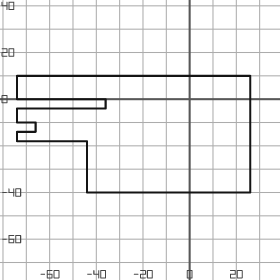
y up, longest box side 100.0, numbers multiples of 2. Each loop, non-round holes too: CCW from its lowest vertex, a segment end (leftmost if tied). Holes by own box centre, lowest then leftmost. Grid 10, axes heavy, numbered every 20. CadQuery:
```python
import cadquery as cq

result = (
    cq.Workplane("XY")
    .moveTo(-44.0, -40.0)
    .lineTo(26.0, -40.0)
    .lineTo(26.0, 10.0)
    .lineTo(-74.0, 10.0)
    .lineTo(-74.0, 0.0)
    .lineTo(-36.0, 0.0)
    .lineTo(-36.0, -4.0)
    .lineTo(-74.0, -4.0)
    .lineTo(-74.0, -10.0)
    .lineTo(-66.0, -10.0)
    .lineTo(-66.0, -14.0)
    .lineTo(-74.0, -14.0)
    .lineTo(-74.0, -18.0)
    .lineTo(-44.0, -18.0)
    .close()
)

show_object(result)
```